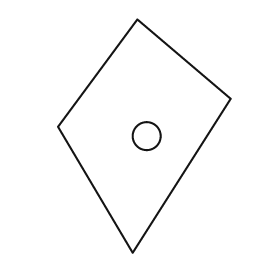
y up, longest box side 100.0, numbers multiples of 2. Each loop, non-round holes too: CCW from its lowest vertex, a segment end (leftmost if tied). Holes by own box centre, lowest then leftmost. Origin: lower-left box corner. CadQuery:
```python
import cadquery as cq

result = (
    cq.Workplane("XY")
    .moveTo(32.0, 0.0)
    .lineTo(74.0, 66.0)
    .lineTo(34.0, 100.0)
    .lineTo(0.0, 54.0)
    .close()
    .moveTo(38.0, 50.0)
    .circle(6.0)
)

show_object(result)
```